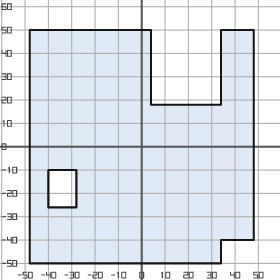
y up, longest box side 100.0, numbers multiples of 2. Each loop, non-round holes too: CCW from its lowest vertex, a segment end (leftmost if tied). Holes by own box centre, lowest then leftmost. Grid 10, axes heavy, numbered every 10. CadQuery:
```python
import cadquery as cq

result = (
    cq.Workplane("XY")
    .moveTo(-48.0, -50.0)
    .lineTo(34.0, -50.0)
    .lineTo(34.0, -40.0)
    .lineTo(48.0, -40.0)
    .lineTo(48.0, 50.0)
    .lineTo(34.0, 50.0)
    .lineTo(34.0, 18.0)
    .lineTo(4.0, 18.0)
    .lineTo(4.0, 50.0)
    .lineTo(-48.0, 50.0)
    .close()
    .moveTo(-40.0, -26.0)
    .lineTo(-28.0, -26.0)
    .lineTo(-28.0, -10.0)
    .lineTo(-40.0, -10.0)
    .close()
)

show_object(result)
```